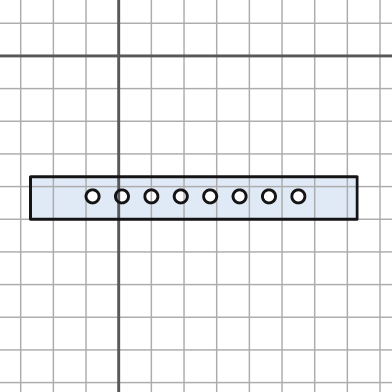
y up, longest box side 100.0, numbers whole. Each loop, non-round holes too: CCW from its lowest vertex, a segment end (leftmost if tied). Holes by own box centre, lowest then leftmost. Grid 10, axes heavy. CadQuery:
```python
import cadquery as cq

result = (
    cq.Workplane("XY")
    .moveTo(-27.0, -50.0)
    .lineTo(73.0, -50.0)
    .lineTo(73.0, -37.0)
    .lineTo(-27.0, -37.0)
    .close()
    .moveTo(-8.0, -43.0)
    .circle(2.0)
    .moveTo(1.0, -43.0)
    .circle(2.0)
    .moveTo(10.0, -43.0)
    .circle(2.0)
    .moveTo(19.0, -43.0)
    .circle(2.0)
    .moveTo(28.0, -43.0)
    .circle(2.0)
    .moveTo(37.0, -43.0)
    .circle(2.0)
    .moveTo(46.0, -43.0)
    .circle(2.0)
    .moveTo(55.0, -43.0)
    .circle(2.0)
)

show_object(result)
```